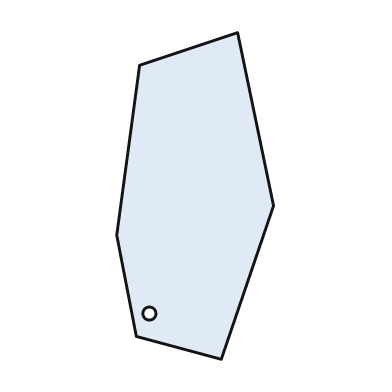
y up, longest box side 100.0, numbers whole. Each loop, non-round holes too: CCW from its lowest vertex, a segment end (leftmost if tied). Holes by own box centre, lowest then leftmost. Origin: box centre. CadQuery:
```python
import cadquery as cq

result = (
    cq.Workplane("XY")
    .moveTo(8.0, -50.0)
    .lineTo(24.0, -3.0)
    .lineTo(13.0, 50.0)
    .lineTo(-17.0, 40.0)
    .lineTo(-24.0, -12.0)
    .lineTo(-18.0, -43.0)
    .close()
    .moveTo(-14.0, -36.0)
    .circle(2.0)
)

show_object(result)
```